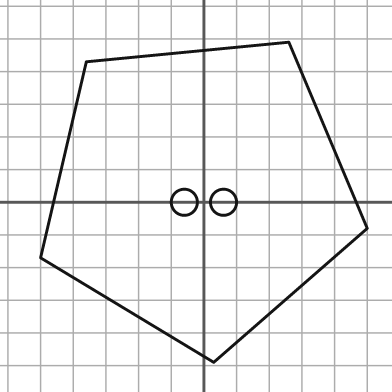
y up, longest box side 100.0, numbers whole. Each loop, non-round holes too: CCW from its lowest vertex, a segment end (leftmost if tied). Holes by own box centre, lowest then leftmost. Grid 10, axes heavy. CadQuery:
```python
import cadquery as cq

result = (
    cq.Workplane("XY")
    .moveTo(3.0, -49.0)
    .lineTo(50.0, -8.0)
    .lineTo(26.0, 49.0)
    .lineTo(-36.0, 43.0)
    .lineTo(-50.0, -17.0)
    .close()
    .moveTo(-6.0, 0.0)
    .circle(4.0)
    .moveTo(6.0, 0.0)
    .circle(4.0)
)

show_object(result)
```